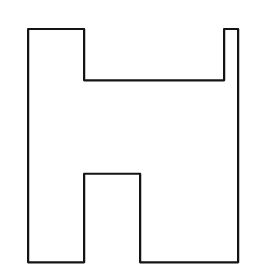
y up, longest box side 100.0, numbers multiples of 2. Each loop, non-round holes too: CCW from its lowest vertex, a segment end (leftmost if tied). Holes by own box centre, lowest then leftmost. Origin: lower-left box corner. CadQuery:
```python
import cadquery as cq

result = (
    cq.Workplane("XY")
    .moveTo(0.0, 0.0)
    .lineTo(24.0, 0.0)
    .lineTo(24.0, 38.0)
    .lineTo(48.0, 38.0)
    .lineTo(48.0, 0.0)
    .lineTo(90.0, 0.0)
    .lineTo(90.0, 100.0)
    .lineTo(84.0, 100.0)
    .lineTo(84.0, 78.0)
    .lineTo(24.0, 78.0)
    .lineTo(24.0, 100.0)
    .lineTo(0.0, 100.0)
    .close()
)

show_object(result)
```